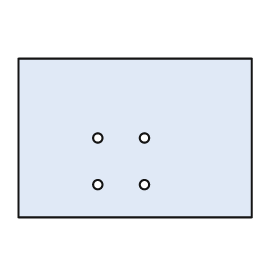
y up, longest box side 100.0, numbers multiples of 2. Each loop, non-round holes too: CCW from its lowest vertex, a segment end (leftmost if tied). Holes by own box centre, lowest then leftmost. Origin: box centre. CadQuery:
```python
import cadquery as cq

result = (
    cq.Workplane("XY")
    .moveTo(-50.0, -34.0)
    .lineTo(50.0, -34.0)
    .lineTo(50.0, 34.0)
    .lineTo(-50.0, 34.0)
    .close()
    .moveTo(-16.0, -20.0)
    .circle(2.0)
    .moveTo(4.0, -20.0)
    .circle(2.0)
    .moveTo(-16.0, 0.0)
    .circle(2.0)
    .moveTo(4.0, 0.0)
    .circle(2.0)
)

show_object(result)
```